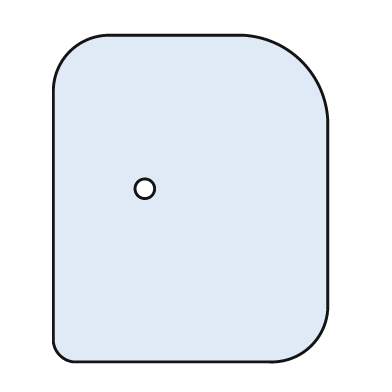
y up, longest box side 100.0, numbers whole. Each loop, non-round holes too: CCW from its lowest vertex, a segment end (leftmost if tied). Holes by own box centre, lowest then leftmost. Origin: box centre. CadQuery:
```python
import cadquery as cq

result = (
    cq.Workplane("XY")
    .moveTo(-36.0, -50.0)
    .lineTo(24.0, -50.0)
    .threePointArc((37.0, -45.0), (42.0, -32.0))
    .lineTo(42.0, 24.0)
    .threePointArc((34.0, 42.0), (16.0, 50.0))
    .lineTo(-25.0, 50.0)
    .threePointArc((-37.0, 45.0), (-42.0, 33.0))
    .lineTo(-42.0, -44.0)
    .threePointArc((-40.0, -48.0), (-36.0, -50.0))
    .close()
    .moveTo(-14.0, 3.0)
    .circle(3.0)
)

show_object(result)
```